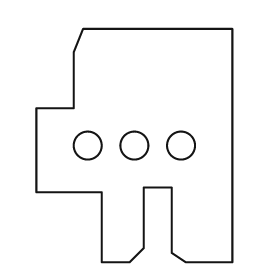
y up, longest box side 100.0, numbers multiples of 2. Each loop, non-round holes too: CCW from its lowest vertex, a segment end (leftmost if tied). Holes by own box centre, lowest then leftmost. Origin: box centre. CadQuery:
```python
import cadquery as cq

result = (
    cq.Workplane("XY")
    .moveTo(-14.0, -50.0)
    .lineTo(-2.0, -50.0)
    .lineTo(4.0, -44.0)
    .lineTo(4.0, -18.0)
    .lineTo(16.0, -18.0)
    .lineTo(16.0, -46.0)
    .lineTo(22.0, -50.0)
    .lineTo(42.0, -50.0)
    .lineTo(42.0, 50.0)
    .lineTo(-22.0, 50.0)
    .lineTo(-26.0, 40.0)
    .lineTo(-26.0, 16.0)
    .lineTo(-42.0, 16.0)
    .lineTo(-42.0, -20.0)
    .lineTo(-14.0, -20.0)
    .close()
    .moveTo(-20.0, 0.0)
    .circle(6.0)
    .moveTo(0.0, 0.0)
    .circle(6.0)
    .moveTo(20.0, 0.0)
    .circle(6.0)
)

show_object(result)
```